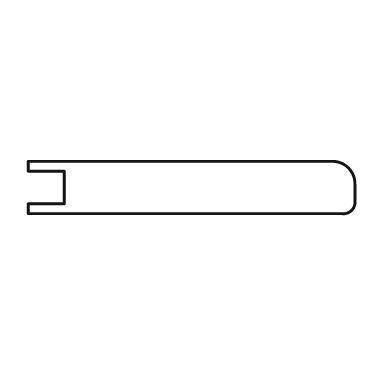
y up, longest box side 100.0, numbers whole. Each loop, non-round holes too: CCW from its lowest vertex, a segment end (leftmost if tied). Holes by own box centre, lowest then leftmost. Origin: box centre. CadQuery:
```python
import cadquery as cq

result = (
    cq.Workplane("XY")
    .moveTo(-50.0, -8.0)
    .lineTo(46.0, -8.0)
    .threePointArc((49.0, -7.0), (50.0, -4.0))
    .lineTo(50.0, 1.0)
    .threePointArc((48.0, 6.0), (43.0, 8.0))
    .lineTo(-50.0, 8.0)
    .lineTo(-50.0, 5.0)
    .lineTo(-39.0, 5.0)
    .lineTo(-39.0, -5.0)
    .lineTo(-50.0, -5.0)
    .close()
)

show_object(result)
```